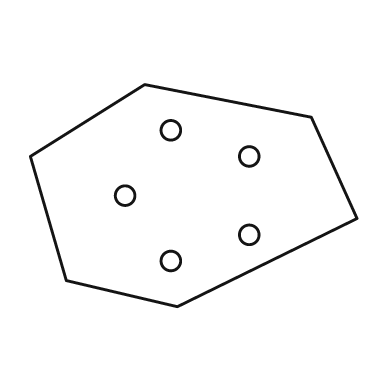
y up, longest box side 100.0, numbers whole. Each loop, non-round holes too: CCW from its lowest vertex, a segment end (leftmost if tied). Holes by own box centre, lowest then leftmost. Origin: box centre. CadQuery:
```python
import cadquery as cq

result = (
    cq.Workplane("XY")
    .moveTo(-5.0, -34.0)
    .lineTo(50.0, -7.0)
    .lineTo(36.0, 24.0)
    .lineTo(-15.0, 34.0)
    .lineTo(-50.0, 12.0)
    .lineTo(-39.0, -26.0)
    .close()
    .moveTo(-7.0, -20.0)
    .circle(3.0)
    .moveTo(17.0, -12.0)
    .circle(3.0)
    .moveTo(-21.0, 0.0)
    .circle(3.0)
    .moveTo(17.0, 12.0)
    .circle(3.0)
    .moveTo(-7.0, 20.0)
    .circle(3.0)
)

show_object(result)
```